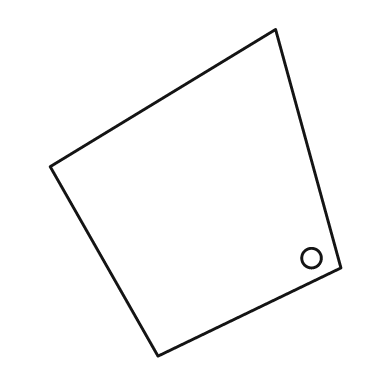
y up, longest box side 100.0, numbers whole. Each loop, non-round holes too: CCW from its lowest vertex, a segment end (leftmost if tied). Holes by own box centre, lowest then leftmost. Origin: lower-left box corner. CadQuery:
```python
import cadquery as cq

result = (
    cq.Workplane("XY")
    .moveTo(33.0, 0.0)
    .lineTo(89.0, 27.0)
    .lineTo(69.0, 100.0)
    .lineTo(0.0, 58.0)
    .close()
    .moveTo(80.0, 30.0)
    .circle(3.0)
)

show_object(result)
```